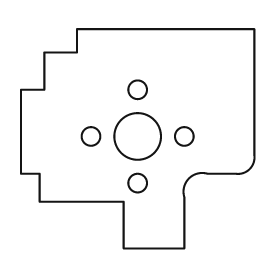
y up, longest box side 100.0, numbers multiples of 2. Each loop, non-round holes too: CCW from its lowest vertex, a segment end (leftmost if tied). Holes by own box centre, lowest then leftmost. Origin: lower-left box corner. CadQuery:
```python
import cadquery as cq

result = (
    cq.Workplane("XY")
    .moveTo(44.0, 0.0)
    .lineTo(70.0, 0.0)
    .lineTo(70.0, 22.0)
    .threePointArc((72.0, 30.0), (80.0, 32.0))
    .lineTo(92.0, 32.0)
    .threePointArc((98.0, 34.0), (100.0, 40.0))
    .lineTo(100.0, 94.0)
    .lineTo(24.0, 94.0)
    .lineTo(24.0, 84.0)
    .lineTo(10.0, 84.0)
    .lineTo(10.0, 68.0)
    .lineTo(0.0, 68.0)
    .lineTo(0.0, 32.0)
    .lineTo(8.0, 32.0)
    .lineTo(8.0, 20.0)
    .lineTo(44.0, 20.0)
    .close()
    .moveTo(50.0, 28.0)
    .circle(4.0)
    .moveTo(30.0, 48.0)
    .circle(4.0)
    .moveTo(50.0, 48.0)
    .circle(10.0)
    .moveTo(70.0, 48.0)
    .circle(4.0)
    .moveTo(50.0, 68.0)
    .circle(4.0)
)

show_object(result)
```